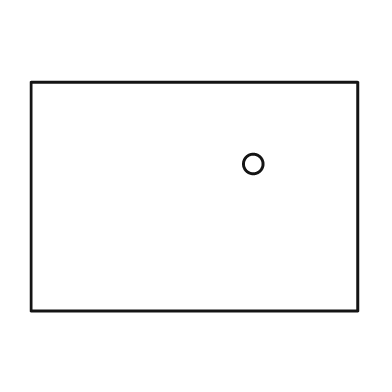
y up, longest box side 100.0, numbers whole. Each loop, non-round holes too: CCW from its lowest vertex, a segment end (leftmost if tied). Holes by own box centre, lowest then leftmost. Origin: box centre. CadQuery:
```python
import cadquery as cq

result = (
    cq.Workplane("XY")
    .moveTo(-50.0, -35.0)
    .lineTo(50.0, -35.0)
    .lineTo(50.0, 35.0)
    .lineTo(-50.0, 35.0)
    .close()
    .moveTo(18.0, 10.0)
    .circle(3.0)
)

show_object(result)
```